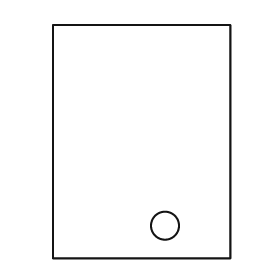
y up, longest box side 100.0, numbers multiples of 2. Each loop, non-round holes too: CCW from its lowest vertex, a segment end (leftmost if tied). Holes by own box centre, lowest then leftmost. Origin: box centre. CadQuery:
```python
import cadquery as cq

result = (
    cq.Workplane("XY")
    .moveTo(-38.0, -50.0)
    .lineTo(38.0, -50.0)
    .lineTo(38.0, 50.0)
    .lineTo(-38.0, 50.0)
    .close()
    .moveTo(10.0, -36.0)
    .circle(6.0)
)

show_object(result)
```